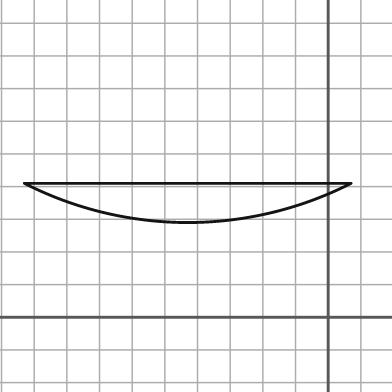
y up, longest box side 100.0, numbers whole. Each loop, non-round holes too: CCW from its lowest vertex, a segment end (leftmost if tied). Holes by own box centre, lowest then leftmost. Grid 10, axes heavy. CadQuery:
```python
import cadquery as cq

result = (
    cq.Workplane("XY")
    .moveTo(-93.0, 41.0)
    .threePointArc((-43.0, 29.0), (7.0, 41.0))
    .close()
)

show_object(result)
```